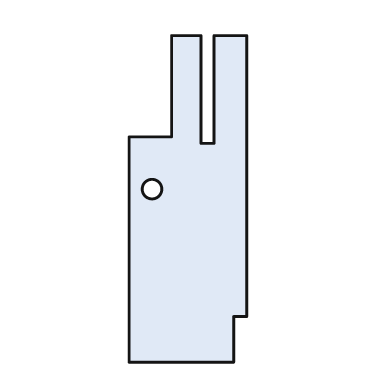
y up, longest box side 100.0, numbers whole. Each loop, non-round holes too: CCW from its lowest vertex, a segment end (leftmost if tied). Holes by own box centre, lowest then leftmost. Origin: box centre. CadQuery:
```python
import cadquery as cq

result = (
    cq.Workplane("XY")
    .moveTo(-18.0, -50.0)
    .lineTo(14.0, -50.0)
    .lineTo(14.0, -36.0)
    .lineTo(18.0, -36.0)
    .lineTo(18.0, 50.0)
    .lineTo(8.0, 50.0)
    .lineTo(8.0, 17.0)
    .lineTo(4.0, 17.0)
    .lineTo(4.0, 50.0)
    .lineTo(-5.0, 50.0)
    .lineTo(-5.0, 19.0)
    .lineTo(-18.0, 19.0)
    .close()
    .moveTo(-11.0, 3.0)
    .circle(3.0)
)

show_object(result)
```